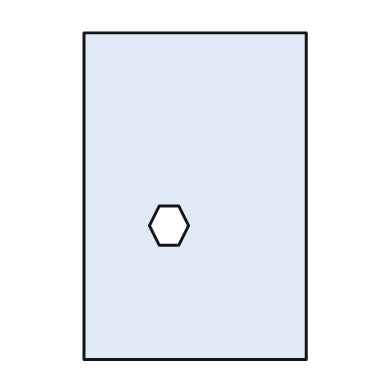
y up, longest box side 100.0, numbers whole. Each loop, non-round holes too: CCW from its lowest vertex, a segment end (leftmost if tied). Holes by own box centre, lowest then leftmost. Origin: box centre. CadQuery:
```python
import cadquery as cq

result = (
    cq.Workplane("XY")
    .moveTo(-34.0, -50.0)
    .lineTo(34.0, -50.0)
    .lineTo(34.0, 50.0)
    .lineTo(-34.0, 50.0)
    .close()
    .moveTo(-11.0, -15.0)
    .lineTo(-5.0, -15.0)
    .lineTo(-2.0, -9.0)
    .lineTo(-5.0, -3.0)
    .lineTo(-11.0, -3.0)
    .lineTo(-14.0, -9.0)
    .close()
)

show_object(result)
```